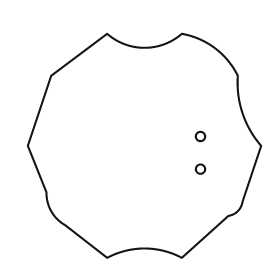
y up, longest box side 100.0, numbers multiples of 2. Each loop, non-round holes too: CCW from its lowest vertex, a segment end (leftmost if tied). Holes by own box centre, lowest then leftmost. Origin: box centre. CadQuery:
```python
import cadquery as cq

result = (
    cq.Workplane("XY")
    .moveTo(-16.0, -48.0)
    .threePointArc((0.0, -44.0), (16.0, -48.0))
    .lineTo(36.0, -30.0)
    .threePointArc((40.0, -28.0), (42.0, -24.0))
    .lineTo(50.0, 0.0)
    .threePointArc((42.0, 14.0), (40.0, 30.0))
    .threePointArc((30.0, 42.0), (16.0, 48.0))
    .threePointArc((0.0, 42.0), (-16.0, 48.0))
    .lineTo(-40.0, 30.0)
    .lineTo(-50.0, 0.0)
    .lineTo(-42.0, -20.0)
    .threePointArc((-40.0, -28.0), (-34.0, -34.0))
    .close()
    .moveTo(24.0, -10.0)
    .circle(2.0)
    .moveTo(24.0, 4.0)
    .circle(2.0)
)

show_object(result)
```